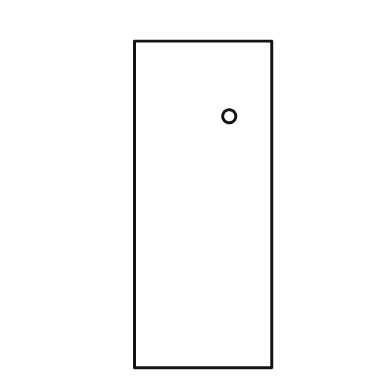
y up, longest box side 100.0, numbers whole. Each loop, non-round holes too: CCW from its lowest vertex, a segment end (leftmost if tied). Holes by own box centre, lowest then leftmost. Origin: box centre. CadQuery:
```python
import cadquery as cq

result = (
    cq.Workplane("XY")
    .moveTo(-21.0, -50.0)
    .lineTo(21.0, -50.0)
    .lineTo(21.0, 50.0)
    .lineTo(-21.0, 50.0)
    .close()
    .moveTo(8.0, 27.0)
    .circle(2.0)
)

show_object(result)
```